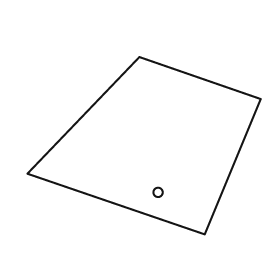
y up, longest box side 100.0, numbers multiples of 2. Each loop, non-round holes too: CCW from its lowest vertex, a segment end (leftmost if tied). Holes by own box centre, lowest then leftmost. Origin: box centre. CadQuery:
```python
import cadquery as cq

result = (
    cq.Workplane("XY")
    .moveTo(26.0, -38.0)
    .lineTo(50.0, 20.0)
    .lineTo(-2.0, 38.0)
    .lineTo(-50.0, -12.0)
    .close()
    .moveTo(6.0, -20.0)
    .circle(2.0)
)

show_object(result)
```